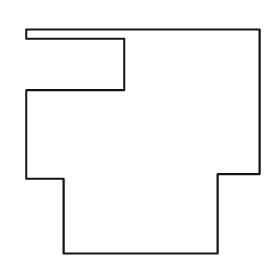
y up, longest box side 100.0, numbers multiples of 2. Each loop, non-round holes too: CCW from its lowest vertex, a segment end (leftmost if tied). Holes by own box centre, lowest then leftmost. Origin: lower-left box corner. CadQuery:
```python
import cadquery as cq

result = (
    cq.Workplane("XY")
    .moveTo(16.0, 0.0)
    .lineTo(82.0, 0.0)
    .lineTo(82.0, 34.0)
    .lineTo(100.0, 34.0)
    .lineTo(100.0, 96.0)
    .lineTo(0.0, 96.0)
    .lineTo(0.0, 92.0)
    .lineTo(42.0, 92.0)
    .lineTo(42.0, 70.0)
    .lineTo(0.0, 70.0)
    .lineTo(0.0, 32.0)
    .lineTo(16.0, 32.0)
    .close()
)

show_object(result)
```